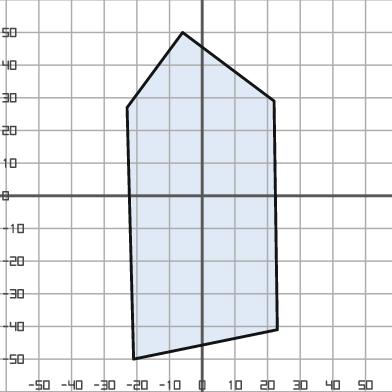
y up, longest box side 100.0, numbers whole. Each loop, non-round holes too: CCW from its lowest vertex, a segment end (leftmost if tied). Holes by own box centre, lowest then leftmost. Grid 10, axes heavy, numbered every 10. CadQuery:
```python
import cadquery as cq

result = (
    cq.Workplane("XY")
    .moveTo(-21.0, -50.0)
    .lineTo(23.0, -41.0)
    .lineTo(22.0, 29.0)
    .lineTo(-6.0, 50.0)
    .lineTo(-23.0, 27.0)
    .close()
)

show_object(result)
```